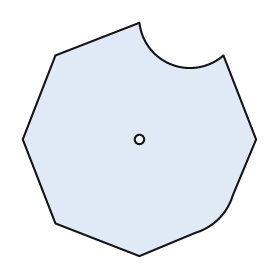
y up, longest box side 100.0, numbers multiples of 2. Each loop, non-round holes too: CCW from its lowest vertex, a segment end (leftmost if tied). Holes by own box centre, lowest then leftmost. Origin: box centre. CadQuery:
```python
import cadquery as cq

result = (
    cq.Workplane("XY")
    .moveTo(0.0, -50.0)
    .lineTo(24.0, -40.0)
    .threePointArc((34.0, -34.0), (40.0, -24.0))
    .lineTo(50.0, 0.0)
    .lineTo(36.0, 36.0)
    .threePointArc((14.0, 32.0), (0.0, 50.0))
    .lineTo(-36.0, 36.0)
    .lineTo(-50.0, 0.0)
    .lineTo(-36.0, -36.0)
    .close()
    .moveTo(0.0, 0.0)
    .circle(2.0)
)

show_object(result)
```